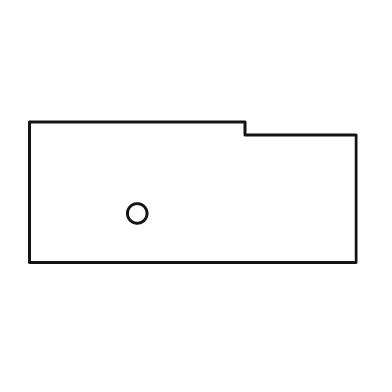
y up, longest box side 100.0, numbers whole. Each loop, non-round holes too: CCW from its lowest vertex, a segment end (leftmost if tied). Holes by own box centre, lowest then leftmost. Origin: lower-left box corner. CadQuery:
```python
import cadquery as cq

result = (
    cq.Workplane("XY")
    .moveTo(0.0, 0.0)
    .lineTo(100.0, 0.0)
    .lineTo(100.0, 39.0)
    .lineTo(66.0, 39.0)
    .lineTo(66.0, 43.0)
    .lineTo(0.0, 43.0)
    .close()
    .moveTo(33.0, 15.0)
    .circle(3.0)
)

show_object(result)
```